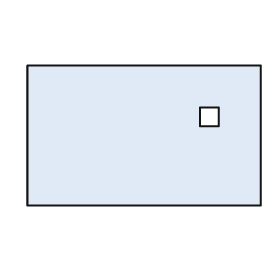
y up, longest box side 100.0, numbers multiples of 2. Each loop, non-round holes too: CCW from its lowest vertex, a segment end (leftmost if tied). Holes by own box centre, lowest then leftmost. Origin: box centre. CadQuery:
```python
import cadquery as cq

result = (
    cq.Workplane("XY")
    .moveTo(-50.0, -30.0)
    .lineTo(50.0, -30.0)
    .lineTo(50.0, 30.0)
    .lineTo(-50.0, 30.0)
    .close()
    .moveTo(24.0, 4.0)
    .lineTo(32.0, 4.0)
    .lineTo(32.0, 12.0)
    .lineTo(24.0, 12.0)
    .close()
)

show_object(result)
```